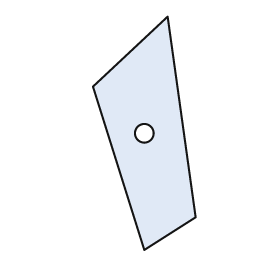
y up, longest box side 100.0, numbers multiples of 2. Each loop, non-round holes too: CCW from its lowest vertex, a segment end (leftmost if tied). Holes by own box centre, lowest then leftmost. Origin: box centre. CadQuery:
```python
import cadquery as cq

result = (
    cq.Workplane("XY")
    .moveTo(0.0, -50.0)
    .lineTo(22.0, -36.0)
    .lineTo(10.0, 50.0)
    .lineTo(-22.0, 20.0)
    .close()
    .moveTo(0.0, 0.0)
    .circle(4.0)
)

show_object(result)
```